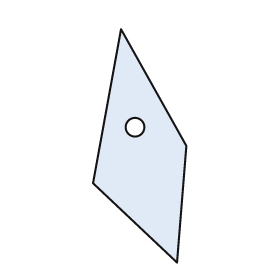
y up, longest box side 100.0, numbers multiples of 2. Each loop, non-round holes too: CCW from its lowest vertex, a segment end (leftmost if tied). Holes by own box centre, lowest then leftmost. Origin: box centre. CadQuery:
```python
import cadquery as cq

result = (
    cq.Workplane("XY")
    .moveTo(16.0, -50.0)
    .lineTo(20.0, 0.0)
    .lineTo(-8.0, 50.0)
    .lineTo(-20.0, -16.0)
    .close()
    .moveTo(-2.0, 8.0)
    .circle(4.0)
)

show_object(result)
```